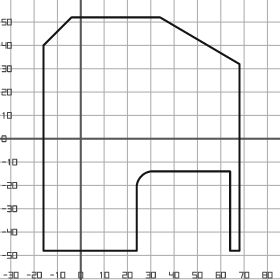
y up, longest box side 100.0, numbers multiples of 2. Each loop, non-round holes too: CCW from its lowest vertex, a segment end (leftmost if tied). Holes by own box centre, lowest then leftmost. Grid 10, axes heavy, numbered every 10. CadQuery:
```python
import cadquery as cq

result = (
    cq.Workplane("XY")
    .moveTo(-16.0, -48.0)
    .lineTo(24.0, -48.0)
    .lineTo(24.0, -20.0)
    .threePointArc((26.0, -16.0), (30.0, -14.0))
    .lineTo(64.0, -14.0)
    .lineTo(64.0, -48.0)
    .lineTo(68.0, -48.0)
    .lineTo(68.0, 32.0)
    .lineTo(34.0, 52.0)
    .lineTo(-4.0, 52.0)
    .lineTo(-16.0, 40.0)
    .close()
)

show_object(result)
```